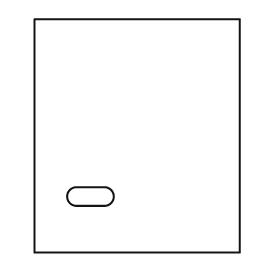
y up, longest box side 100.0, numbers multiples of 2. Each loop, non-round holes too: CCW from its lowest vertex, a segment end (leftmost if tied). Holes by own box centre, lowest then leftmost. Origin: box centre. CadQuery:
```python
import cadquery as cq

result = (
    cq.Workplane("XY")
    .moveTo(-44.0, -50.0)
    .lineTo(44.0, -50.0)
    .lineTo(44.0, 50.0)
    .lineTo(-44.0, 50.0)
    .close()
    .moveTo(-26.0, -30.0)
    .lineTo(-14.0, -30.0)
    .threePointArc((-10.0, -26.0), (-14.0, -22.0))
    .lineTo(-26.0, -22.0)
    .threePointArc((-30.0, -26.0), (-26.0, -30.0))
    .close()
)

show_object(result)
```